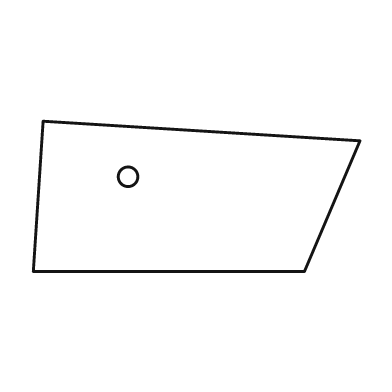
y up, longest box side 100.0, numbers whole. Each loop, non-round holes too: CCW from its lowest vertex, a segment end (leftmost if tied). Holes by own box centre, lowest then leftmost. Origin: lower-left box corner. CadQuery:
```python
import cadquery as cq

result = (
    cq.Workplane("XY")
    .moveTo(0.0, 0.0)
    .lineTo(83.0, 0.0)
    .lineTo(100.0, 40.0)
    .lineTo(3.0, 46.0)
    .close()
    .moveTo(29.0, 29.0)
    .circle(3.0)
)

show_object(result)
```